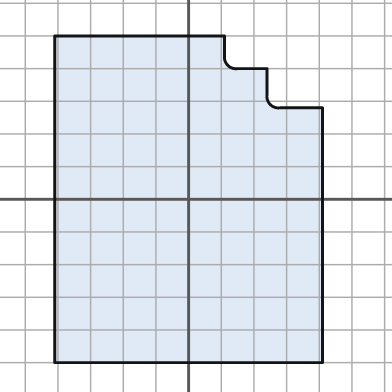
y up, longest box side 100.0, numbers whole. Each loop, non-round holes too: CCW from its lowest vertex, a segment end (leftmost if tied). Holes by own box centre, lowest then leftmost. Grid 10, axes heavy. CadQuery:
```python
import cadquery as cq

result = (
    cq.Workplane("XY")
    .moveTo(-41.0, -50.0)
    .lineTo(41.0, -50.0)
    .lineTo(41.0, 28.0)
    .lineTo(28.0, 28.0)
    .threePointArc((25.0, 29.0), (24.0, 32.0))
    .lineTo(24.0, 40.0)
    .lineTo(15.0, 40.0)
    .threePointArc((12.0, 41.0), (11.0, 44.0))
    .lineTo(11.0, 50.0)
    .lineTo(-41.0, 50.0)
    .close()
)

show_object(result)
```